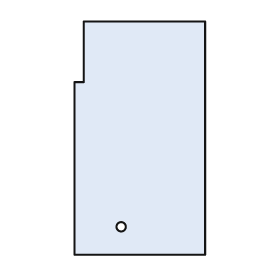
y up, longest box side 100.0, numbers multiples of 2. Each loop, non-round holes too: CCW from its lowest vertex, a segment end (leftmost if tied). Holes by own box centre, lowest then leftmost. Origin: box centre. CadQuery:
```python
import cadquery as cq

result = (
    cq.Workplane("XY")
    .moveTo(-28.0, -50.0)
    .lineTo(28.0, -50.0)
    .lineTo(28.0, 50.0)
    .lineTo(-24.0, 50.0)
    .lineTo(-24.0, 24.0)
    .lineTo(-28.0, 24.0)
    .close()
    .moveTo(-8.0, -38.0)
    .circle(2.0)
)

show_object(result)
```